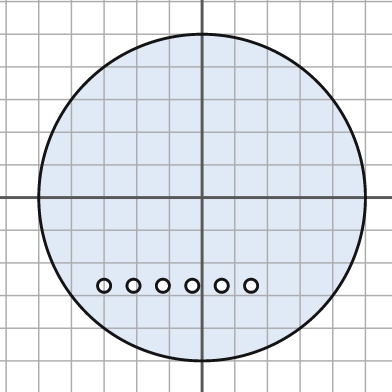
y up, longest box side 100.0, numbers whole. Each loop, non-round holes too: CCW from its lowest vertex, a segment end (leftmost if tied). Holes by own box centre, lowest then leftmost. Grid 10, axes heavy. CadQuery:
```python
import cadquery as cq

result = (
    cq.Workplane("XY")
    .moveTo(0.0, 0.0)
    .circle(50.0)
    .moveTo(-30.0, -27.0)
    .circle(2.0)
    .moveTo(-21.0, -27.0)
    .circle(2.0)
    .moveTo(-12.0, -27.0)
    .circle(2.0)
    .moveTo(-3.0, -27.0)
    .circle(2.0)
    .moveTo(6.0, -27.0)
    .circle(2.0)
    .moveTo(15.0, -27.0)
    .circle(2.0)
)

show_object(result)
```